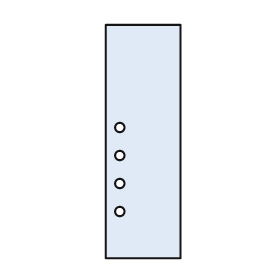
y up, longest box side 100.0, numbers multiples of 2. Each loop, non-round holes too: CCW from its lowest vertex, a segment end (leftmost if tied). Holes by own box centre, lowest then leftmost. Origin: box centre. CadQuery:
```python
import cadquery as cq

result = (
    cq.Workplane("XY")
    .moveTo(-16.0, -50.0)
    .lineTo(16.0, -50.0)
    .lineTo(16.0, 50.0)
    .lineTo(-16.0, 50.0)
    .close()
    .moveTo(-10.0, -30.0)
    .circle(2.0)
    .moveTo(-10.0, -18.0)
    .circle(2.0)
    .moveTo(-10.0, -6.0)
    .circle(2.0)
    .moveTo(-10.0, 6.0)
    .circle(2.0)
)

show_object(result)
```